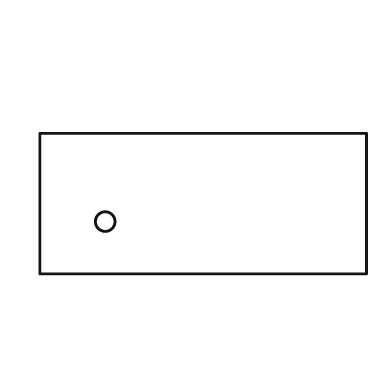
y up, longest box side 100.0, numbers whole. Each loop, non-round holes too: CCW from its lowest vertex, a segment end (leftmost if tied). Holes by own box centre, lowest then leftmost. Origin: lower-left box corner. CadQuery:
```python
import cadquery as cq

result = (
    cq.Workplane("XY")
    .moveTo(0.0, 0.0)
    .lineTo(100.0, 0.0)
    .lineTo(100.0, 43.0)
    .lineTo(0.0, 43.0)
    .close()
    .moveTo(20.0, 16.0)
    .circle(3.0)
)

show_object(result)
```